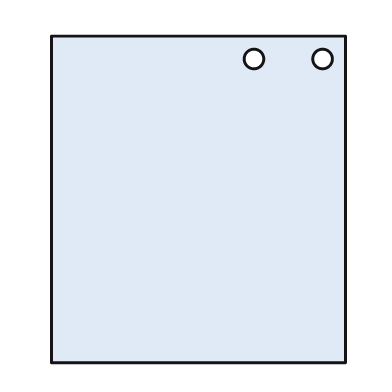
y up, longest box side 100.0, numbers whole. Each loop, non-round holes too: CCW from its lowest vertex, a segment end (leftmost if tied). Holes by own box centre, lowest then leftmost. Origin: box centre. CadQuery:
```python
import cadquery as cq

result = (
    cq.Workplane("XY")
    .moveTo(-45.0, -50.0)
    .lineTo(45.0, -50.0)
    .lineTo(45.0, 50.0)
    .lineTo(-45.0, 50.0)
    .close()
    .moveTo(17.0, 43.0)
    .circle(3.0)
    .moveTo(38.0, 43.0)
    .circle(3.0)
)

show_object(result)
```